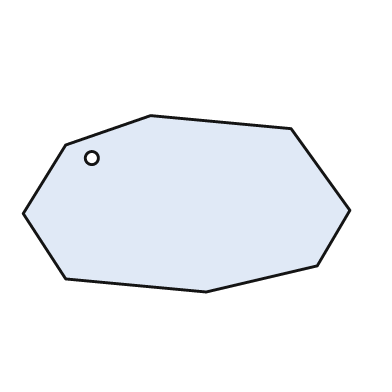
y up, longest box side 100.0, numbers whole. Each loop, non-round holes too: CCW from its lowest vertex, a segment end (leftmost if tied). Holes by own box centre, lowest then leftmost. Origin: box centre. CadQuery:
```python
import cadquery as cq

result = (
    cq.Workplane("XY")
    .moveTo(6.0, -27.0)
    .lineTo(40.0, -19.0)
    .lineTo(50.0, -2.0)
    .lineTo(32.0, 23.0)
    .lineTo(-11.0, 27.0)
    .lineTo(-37.0, 18.0)
    .lineTo(-50.0, -3.0)
    .lineTo(-37.0, -23.0)
    .close()
    .moveTo(-29.0, 14.0)
    .circle(2.0)
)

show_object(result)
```